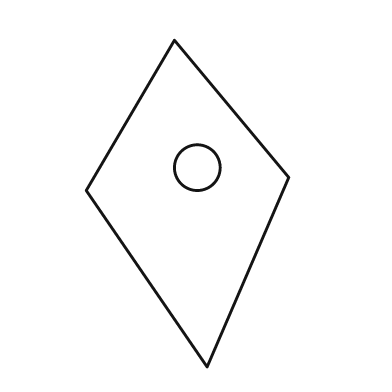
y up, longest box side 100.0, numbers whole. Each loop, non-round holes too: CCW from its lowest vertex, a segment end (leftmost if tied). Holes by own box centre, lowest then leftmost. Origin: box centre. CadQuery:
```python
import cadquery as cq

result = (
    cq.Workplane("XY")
    .moveTo(6.0, -50.0)
    .lineTo(31.0, 8.0)
    .lineTo(-4.0, 50.0)
    .lineTo(-31.0, 4.0)
    .close()
    .moveTo(3.0, 11.0)
    .circle(7.0)
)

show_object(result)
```